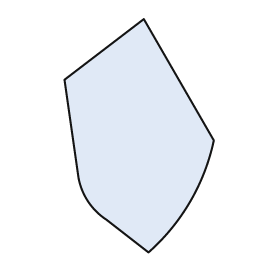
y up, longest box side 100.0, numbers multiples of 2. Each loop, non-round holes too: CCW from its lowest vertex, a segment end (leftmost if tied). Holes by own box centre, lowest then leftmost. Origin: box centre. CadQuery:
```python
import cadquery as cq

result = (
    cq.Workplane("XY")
    .moveTo(4.0, -50.0)
    .threePointArc((22.0, -28.0), (32.0, -2.0))
    .lineTo(2.0, 50.0)
    .lineTo(-32.0, 24.0)
    .lineTo(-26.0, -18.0)
    .threePointArc((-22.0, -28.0), (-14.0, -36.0))
    .close()
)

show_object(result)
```